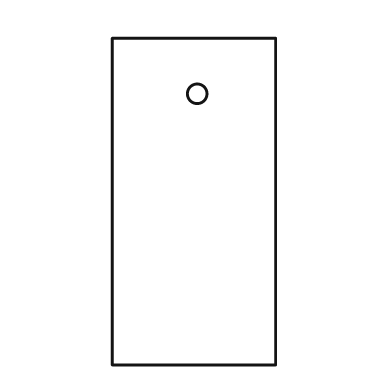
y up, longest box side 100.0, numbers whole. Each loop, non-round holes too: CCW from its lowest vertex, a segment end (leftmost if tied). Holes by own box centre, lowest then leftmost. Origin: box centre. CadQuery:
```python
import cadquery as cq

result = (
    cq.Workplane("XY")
    .moveTo(-25.0, -50.0)
    .lineTo(25.0, -50.0)
    .lineTo(25.0, 50.0)
    .lineTo(-25.0, 50.0)
    .close()
    .moveTo(1.0, 33.0)
    .circle(3.0)
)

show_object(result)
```